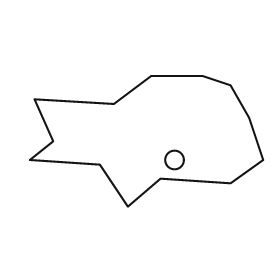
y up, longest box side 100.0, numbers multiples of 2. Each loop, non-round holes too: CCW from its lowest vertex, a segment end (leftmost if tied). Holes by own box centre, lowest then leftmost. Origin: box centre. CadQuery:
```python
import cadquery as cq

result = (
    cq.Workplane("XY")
    .moveTo(-8.0, -28.0)
    .lineTo(6.0, -16.0)
    .lineTo(36.0, -18.0)
    .lineTo(50.0, -8.0)
    .lineTo(44.0, 10.0)
    .lineTo(36.0, 24.0)
    .lineTo(24.0, 28.0)
    .lineTo(2.0, 28.0)
    .lineTo(-14.0, 16.0)
    .lineTo(-48.0, 18.0)
    .lineTo(-40.0, 0.0)
    .lineTo(-50.0, -8.0)
    .lineTo(-20.0, -10.0)
    .close()
    .moveTo(12.0, -8.0)
    .circle(4.0)
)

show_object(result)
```